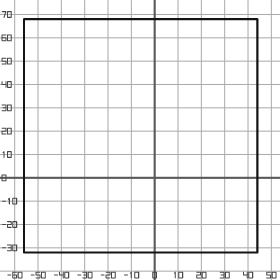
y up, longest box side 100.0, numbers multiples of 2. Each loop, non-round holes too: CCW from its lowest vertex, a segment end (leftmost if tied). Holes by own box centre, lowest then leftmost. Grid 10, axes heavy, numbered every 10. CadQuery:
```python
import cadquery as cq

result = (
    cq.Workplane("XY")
    .moveTo(-56.0, -32.0)
    .lineTo(44.0, -32.0)
    .lineTo(44.0, 68.0)
    .lineTo(-56.0, 68.0)
    .close()
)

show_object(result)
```